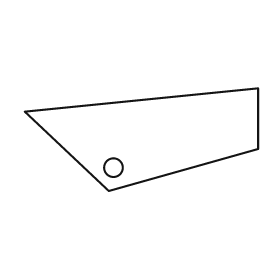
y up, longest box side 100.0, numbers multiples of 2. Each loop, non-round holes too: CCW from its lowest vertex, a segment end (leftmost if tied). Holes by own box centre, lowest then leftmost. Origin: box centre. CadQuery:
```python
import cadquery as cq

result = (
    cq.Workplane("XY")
    .moveTo(-14.0, -22.0)
    .lineTo(50.0, -4.0)
    .lineTo(50.0, 22.0)
    .lineTo(-50.0, 12.0)
    .close()
    .moveTo(-12.0, -12.0)
    .circle(4.0)
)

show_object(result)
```